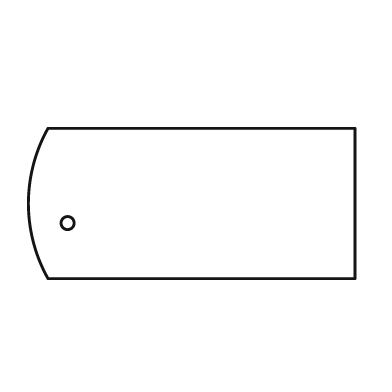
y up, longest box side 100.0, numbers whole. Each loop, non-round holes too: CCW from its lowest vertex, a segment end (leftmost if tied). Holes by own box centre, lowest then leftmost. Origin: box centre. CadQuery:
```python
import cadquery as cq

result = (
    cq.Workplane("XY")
    .moveTo(-44.0, -23.0)
    .lineTo(50.0, -23.0)
    .lineTo(50.0, 23.0)
    .lineTo(-44.0, 23.0)
    .threePointArc((-50.0, 0.0), (-44.0, -23.0))
    .close()
    .moveTo(-38.0, -6.0)
    .circle(2.0)
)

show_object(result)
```